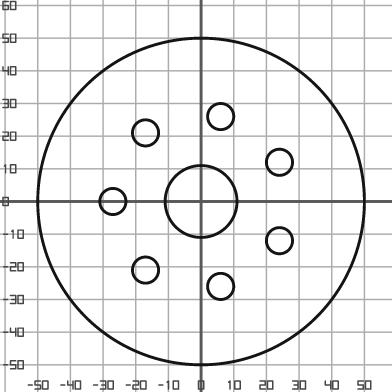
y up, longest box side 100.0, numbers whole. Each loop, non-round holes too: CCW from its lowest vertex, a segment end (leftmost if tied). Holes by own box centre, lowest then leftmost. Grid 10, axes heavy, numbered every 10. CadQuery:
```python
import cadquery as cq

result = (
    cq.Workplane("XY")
    .moveTo(0.0, 0.0)
    .circle(50.0)
    .moveTo(6.0, -26.0)
    .circle(4.0)
    .moveTo(-17.0, -21.0)
    .circle(4.0)
    .moveTo(24.0, -12.0)
    .circle(4.0)
    .moveTo(-27.0, 0.0)
    .circle(4.0)
    .moveTo(0.0, 0.0)
    .circle(11.0)
    .moveTo(24.0, 12.0)
    .circle(4.0)
    .moveTo(-17.0, 21.0)
    .circle(4.0)
    .moveTo(6.0, 26.0)
    .circle(4.0)
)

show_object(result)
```